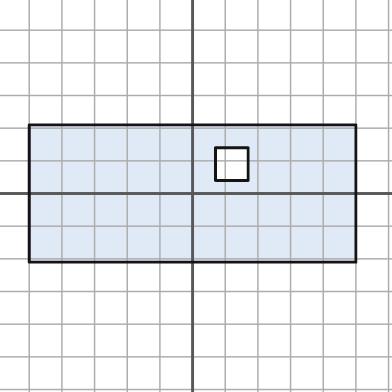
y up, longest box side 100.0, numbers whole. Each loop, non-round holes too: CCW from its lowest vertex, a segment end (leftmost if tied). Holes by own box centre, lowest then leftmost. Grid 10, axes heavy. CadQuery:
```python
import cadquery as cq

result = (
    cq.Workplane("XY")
    .moveTo(-50.0, -21.0)
    .lineTo(50.0, -21.0)
    .lineTo(50.0, 21.0)
    .lineTo(-50.0, 21.0)
    .close()
    .moveTo(7.0, 4.0)
    .lineTo(17.0, 4.0)
    .lineTo(17.0, 14.0)
    .lineTo(7.0, 14.0)
    .close()
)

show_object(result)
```